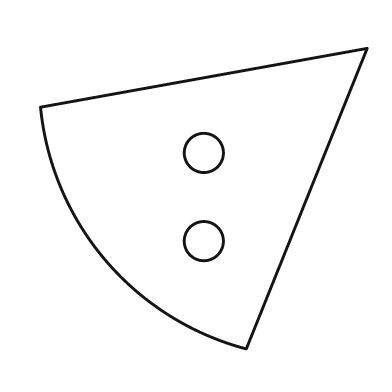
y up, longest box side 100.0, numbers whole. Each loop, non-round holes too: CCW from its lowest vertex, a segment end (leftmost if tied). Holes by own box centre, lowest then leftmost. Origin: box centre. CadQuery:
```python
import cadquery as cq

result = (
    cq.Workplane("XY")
    .moveTo(13.0, -46.0)
    .lineTo(50.0, 46.0)
    .lineTo(-50.0, 28.0)
    .threePointArc((-30.0, -19.0), (13.0, -46.0))
    .close()
    .moveTo(0.0, -13.0)
    .circle(6.0)
    .moveTo(0.0, 14.0)
    .circle(6.0)
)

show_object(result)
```